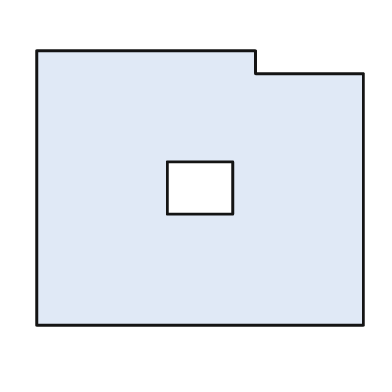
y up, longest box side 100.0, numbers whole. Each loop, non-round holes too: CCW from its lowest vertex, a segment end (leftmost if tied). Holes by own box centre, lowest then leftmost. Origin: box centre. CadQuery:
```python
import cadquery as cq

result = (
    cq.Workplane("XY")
    .moveTo(-50.0, -42.0)
    .lineTo(50.0, -42.0)
    .lineTo(50.0, 35.0)
    .lineTo(17.0, 35.0)
    .lineTo(17.0, 42.0)
    .lineTo(-50.0, 42.0)
    .close()
    .moveTo(-10.0, -8.0)
    .lineTo(10.0, -8.0)
    .lineTo(10.0, 8.0)
    .lineTo(-10.0, 8.0)
    .close()
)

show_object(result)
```